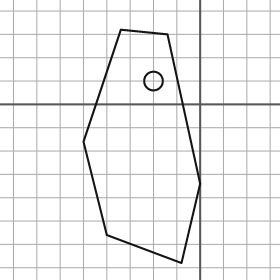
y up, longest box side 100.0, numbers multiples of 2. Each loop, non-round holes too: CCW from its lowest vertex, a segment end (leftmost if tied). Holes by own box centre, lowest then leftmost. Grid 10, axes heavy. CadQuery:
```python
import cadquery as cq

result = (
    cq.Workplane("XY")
    .moveTo(-8.0, -68.0)
    .lineTo(0.0, -34.0)
    .lineTo(-14.0, 30.0)
    .lineTo(-34.0, 32.0)
    .lineTo(-50.0, -16.0)
    .lineTo(-40.0, -56.0)
    .close()
    .moveTo(-20.0, 10.0)
    .circle(4.0)
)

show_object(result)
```